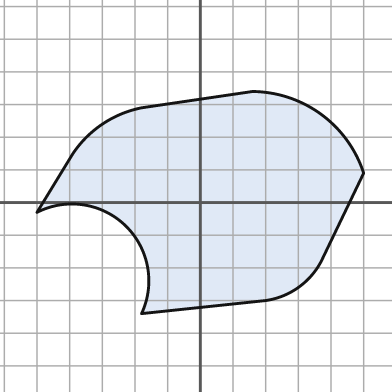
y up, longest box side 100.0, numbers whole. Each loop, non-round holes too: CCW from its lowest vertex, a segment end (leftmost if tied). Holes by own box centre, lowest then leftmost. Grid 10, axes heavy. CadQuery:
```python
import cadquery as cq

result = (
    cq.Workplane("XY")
    .moveTo(-18.0, -34.0)
    .lineTo(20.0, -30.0)
    .threePointArc((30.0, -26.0), (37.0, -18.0))
    .lineTo(50.0, 9.0)
    .threePointArc((37.0, 27.0), (16.0, 34.0))
    .lineTo(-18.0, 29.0)
    .threePointArc((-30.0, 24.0), (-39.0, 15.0))
    .lineTo(-50.0, -3.0)
    .threePointArc((-23.0, -7.0), (-18.0, -34.0))
    .close()
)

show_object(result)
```